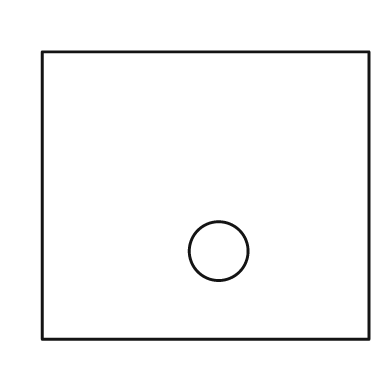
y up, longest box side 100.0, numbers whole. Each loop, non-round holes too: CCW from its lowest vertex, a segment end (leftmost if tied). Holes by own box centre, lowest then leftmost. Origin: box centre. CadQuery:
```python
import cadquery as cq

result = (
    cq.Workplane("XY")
    .moveTo(-50.0, -44.0)
    .lineTo(50.0, -44.0)
    .lineTo(50.0, 44.0)
    .lineTo(-50.0, 44.0)
    .close()
    .moveTo(4.0, -17.0)
    .circle(9.0)
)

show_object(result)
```